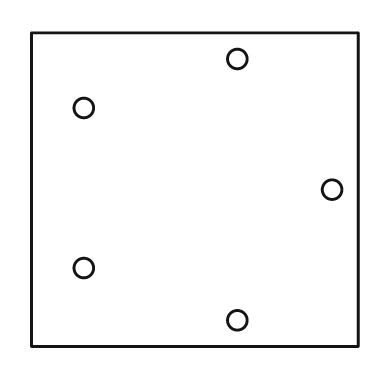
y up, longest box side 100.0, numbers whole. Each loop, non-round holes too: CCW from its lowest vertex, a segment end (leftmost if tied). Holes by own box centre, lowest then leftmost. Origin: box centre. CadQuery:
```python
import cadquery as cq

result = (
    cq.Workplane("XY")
    .moveTo(-50.0, -48.0)
    .lineTo(50.0, -48.0)
    .lineTo(50.0, 48.0)
    .lineTo(-50.0, 48.0)
    .close()
    .moveTo(13.0, -40.0)
    .circle(3.0)
    .moveTo(-34.0, -24.0)
    .circle(3.0)
    .moveTo(42.0, 0.0)
    .circle(3.0)
    .moveTo(-34.0, 25.0)
    .circle(3.0)
    .moveTo(13.0, 40.0)
    .circle(3.0)
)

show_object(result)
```